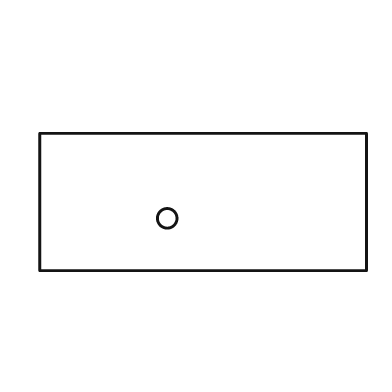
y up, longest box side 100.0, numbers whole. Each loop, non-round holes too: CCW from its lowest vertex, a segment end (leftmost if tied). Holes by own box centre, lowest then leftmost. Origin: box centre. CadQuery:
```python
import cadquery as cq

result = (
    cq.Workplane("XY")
    .moveTo(-50.0, -21.0)
    .lineTo(50.0, -21.0)
    .lineTo(50.0, 21.0)
    .lineTo(-50.0, 21.0)
    .close()
    .moveTo(-11.0, -5.0)
    .circle(3.0)
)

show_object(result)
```